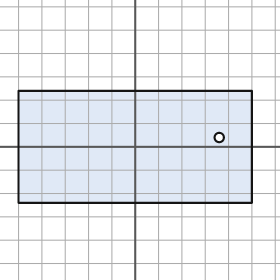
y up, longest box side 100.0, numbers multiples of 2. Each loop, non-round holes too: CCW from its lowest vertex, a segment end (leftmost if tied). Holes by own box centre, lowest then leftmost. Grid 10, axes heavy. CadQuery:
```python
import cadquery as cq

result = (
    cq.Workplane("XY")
    .moveTo(-50.0, -24.0)
    .lineTo(50.0, -24.0)
    .lineTo(50.0, 24.0)
    .lineTo(-50.0, 24.0)
    .close()
    .moveTo(36.0, 4.0)
    .circle(2.0)
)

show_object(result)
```